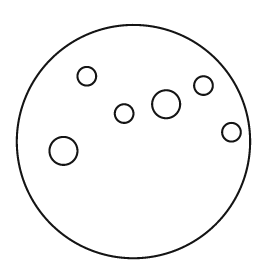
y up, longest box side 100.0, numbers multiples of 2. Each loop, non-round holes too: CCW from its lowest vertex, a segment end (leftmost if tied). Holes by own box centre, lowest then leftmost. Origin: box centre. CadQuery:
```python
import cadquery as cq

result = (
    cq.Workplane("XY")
    .moveTo(0.0, 0.0)
    .circle(50.0)
    .moveTo(-30.0, -4.0)
    .circle(6.0)
    .moveTo(42.0, 4.0)
    .circle(4.0)
    .moveTo(-4.0, 12.0)
    .circle(4.0)
    .moveTo(14.0, 16.0)
    .circle(6.0)
    .moveTo(30.0, 24.0)
    .circle(4.0)
    .moveTo(-20.0, 28.0)
    .circle(4.0)
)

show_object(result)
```